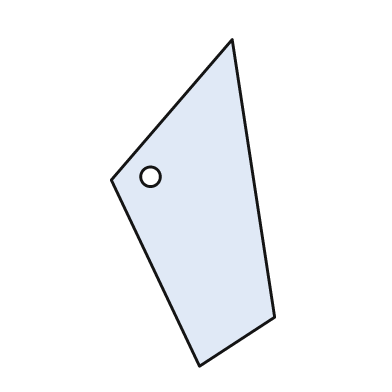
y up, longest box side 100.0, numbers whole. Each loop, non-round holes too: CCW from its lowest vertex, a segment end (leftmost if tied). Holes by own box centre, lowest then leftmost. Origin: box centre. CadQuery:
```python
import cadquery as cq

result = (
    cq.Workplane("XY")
    .moveTo(2.0, -50.0)
    .lineTo(25.0, -35.0)
    .lineTo(12.0, 50.0)
    .lineTo(-25.0, 7.0)
    .close()
    .moveTo(-13.0, 8.0)
    .circle(3.0)
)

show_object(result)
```